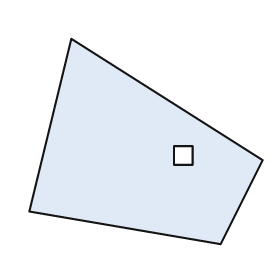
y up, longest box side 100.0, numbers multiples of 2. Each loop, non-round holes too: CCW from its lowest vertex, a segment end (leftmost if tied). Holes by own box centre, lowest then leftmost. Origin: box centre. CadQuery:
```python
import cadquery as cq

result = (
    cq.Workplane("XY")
    .moveTo(32.0, -44.0)
    .lineTo(50.0, -8.0)
    .lineTo(-32.0, 44.0)
    .lineTo(-50.0, -30.0)
    .close()
    .moveTo(12.0, -10.0)
    .lineTo(20.0, -10.0)
    .lineTo(20.0, -2.0)
    .lineTo(12.0, -2.0)
    .close()
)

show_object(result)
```